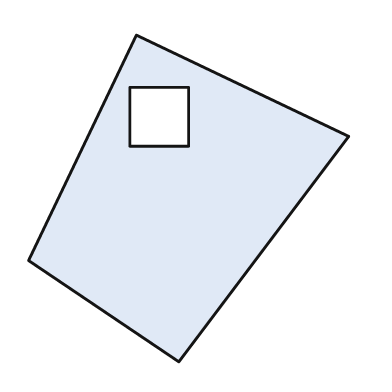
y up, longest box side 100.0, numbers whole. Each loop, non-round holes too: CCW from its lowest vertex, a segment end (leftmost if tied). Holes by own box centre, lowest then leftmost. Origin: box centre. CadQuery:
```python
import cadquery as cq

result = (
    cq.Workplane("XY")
    .moveTo(-3.0, -50.0)
    .lineTo(49.0, 19.0)
    .lineTo(-16.0, 50.0)
    .lineTo(-49.0, -19.0)
    .close()
    .moveTo(-18.0, 16.0)
    .lineTo(0.0, 16.0)
    .lineTo(0.0, 34.0)
    .lineTo(-18.0, 34.0)
    .close()
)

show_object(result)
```